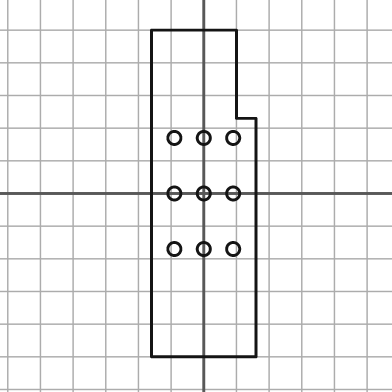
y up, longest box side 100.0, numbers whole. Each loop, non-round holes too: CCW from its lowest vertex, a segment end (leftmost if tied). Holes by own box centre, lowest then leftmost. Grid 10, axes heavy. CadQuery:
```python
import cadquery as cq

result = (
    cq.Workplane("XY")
    .moveTo(-16.0, -50.0)
    .lineTo(16.0, -50.0)
    .lineTo(16.0, 23.0)
    .lineTo(10.0, 23.0)
    .lineTo(10.0, 50.0)
    .lineTo(-16.0, 50.0)
    .close()
    .moveTo(-9.0, -17.0)
    .circle(2.0)
    .moveTo(0.0, -17.0)
    .circle(2.0)
    .moveTo(9.0, -17.0)
    .circle(2.0)
    .moveTo(-9.0, 0.0)
    .circle(2.0)
    .moveTo(0.0, 0.0)
    .circle(2.0)
    .moveTo(9.0, 0.0)
    .circle(2.0)
    .moveTo(-9.0, 17.0)
    .circle(2.0)
    .moveTo(0.0, 17.0)
    .circle(2.0)
    .moveTo(9.0, 17.0)
    .circle(2.0)
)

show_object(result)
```